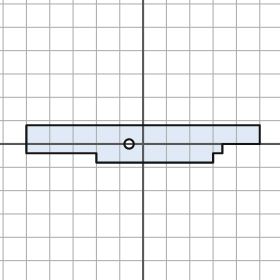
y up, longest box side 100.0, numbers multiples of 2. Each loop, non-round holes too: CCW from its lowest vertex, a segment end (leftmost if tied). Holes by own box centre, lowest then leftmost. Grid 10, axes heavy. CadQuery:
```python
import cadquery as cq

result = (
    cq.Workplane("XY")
    .moveTo(-20.0, -8.0)
    .lineTo(30.0, -8.0)
    .lineTo(30.0, -4.0)
    .lineTo(34.0, -4.0)
    .lineTo(34.0, 0.0)
    .lineTo(50.0, 0.0)
    .lineTo(50.0, 8.0)
    .lineTo(-50.0, 8.0)
    .lineTo(-50.0, -4.0)
    .lineTo(-20.0, -4.0)
    .close()
    .moveTo(-6.0, 0.0)
    .circle(2.0)
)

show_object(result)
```